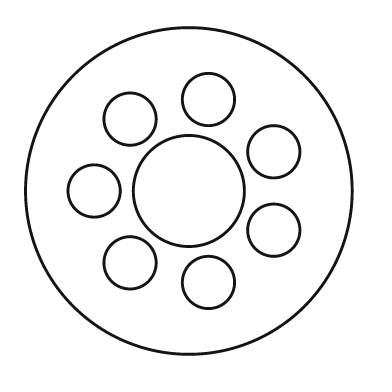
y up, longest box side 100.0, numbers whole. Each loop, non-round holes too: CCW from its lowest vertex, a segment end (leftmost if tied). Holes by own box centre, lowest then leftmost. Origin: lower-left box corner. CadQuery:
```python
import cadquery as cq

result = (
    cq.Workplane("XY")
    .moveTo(50.0, 50.0)
    .circle(50.0)
    .moveTo(56.0, 22.0)
    .circle(8.0)
    .moveTo(32.0, 28.0)
    .circle(8.0)
    .moveTo(76.0, 38.0)
    .circle(8.0)
    .moveTo(21.0, 50.0)
    .circle(8.0)
    .moveTo(50.0, 50.0)
    .circle(17.0)
    .moveTo(76.0, 62.0)
    .circle(8.0)
    .moveTo(32.0, 72.0)
    .circle(8.0)
    .moveTo(56.0, 78.0)
    .circle(8.0)
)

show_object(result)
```